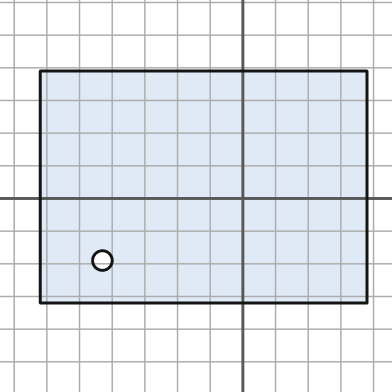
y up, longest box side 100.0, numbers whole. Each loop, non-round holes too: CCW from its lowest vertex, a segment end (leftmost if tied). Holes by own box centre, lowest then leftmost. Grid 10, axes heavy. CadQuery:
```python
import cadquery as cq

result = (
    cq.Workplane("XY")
    .moveTo(-62.0, -32.0)
    .lineTo(38.0, -32.0)
    .lineTo(38.0, 39.0)
    .lineTo(-62.0, 39.0)
    .close()
    .moveTo(-43.0, -19.0)
    .circle(3.0)
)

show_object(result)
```